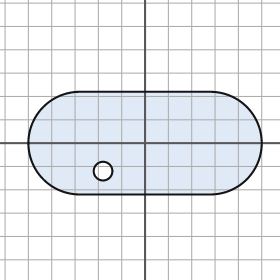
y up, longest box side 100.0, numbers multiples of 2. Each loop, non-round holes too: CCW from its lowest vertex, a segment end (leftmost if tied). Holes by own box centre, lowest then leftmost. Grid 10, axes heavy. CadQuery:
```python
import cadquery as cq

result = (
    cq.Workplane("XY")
    .moveTo(-28.0, -22.0)
    .lineTo(28.0, -22.0)
    .threePointArc((50.0, 0.0), (28.0, 22.0))
    .lineTo(-28.0, 22.0)
    .threePointArc((-50.0, 0.0), (-28.0, -22.0))
    .close()
    .moveTo(-18.0, -12.0)
    .circle(4.0)
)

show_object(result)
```